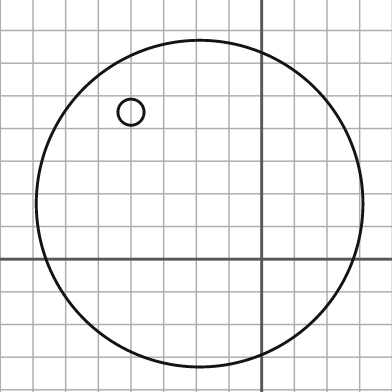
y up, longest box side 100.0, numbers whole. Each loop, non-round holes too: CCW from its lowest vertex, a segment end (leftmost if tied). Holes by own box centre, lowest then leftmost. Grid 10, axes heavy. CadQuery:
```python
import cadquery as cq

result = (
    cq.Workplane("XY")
    .moveTo(-19.0, 17.0)
    .circle(50.0)
    .moveTo(-40.0, 45.0)
    .circle(4.0)
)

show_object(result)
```